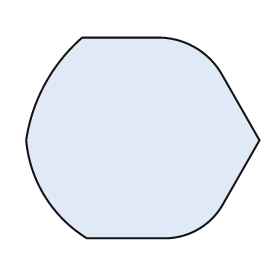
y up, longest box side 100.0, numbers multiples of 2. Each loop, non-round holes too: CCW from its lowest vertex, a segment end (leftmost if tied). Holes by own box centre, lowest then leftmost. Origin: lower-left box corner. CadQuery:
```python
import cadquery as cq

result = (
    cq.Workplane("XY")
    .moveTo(26.0, 0.0)
    .lineTo(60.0, 0.0)
    .threePointArc((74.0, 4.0), (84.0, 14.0))
    .lineTo(100.0, 42.0)
    .lineTo(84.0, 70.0)
    .threePointArc((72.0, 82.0), (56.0, 86.0))
    .lineTo(24.0, 86.0)
    .threePointArc((8.0, 66.0), (0.0, 42.0))
    .threePointArc((8.0, 18.0), (26.0, 0.0))
    .close()
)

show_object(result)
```